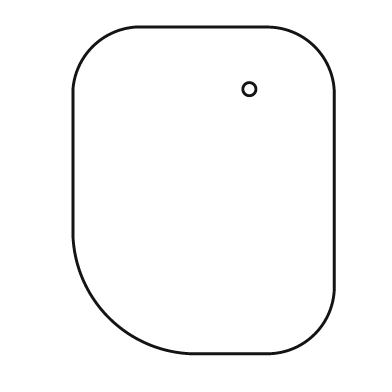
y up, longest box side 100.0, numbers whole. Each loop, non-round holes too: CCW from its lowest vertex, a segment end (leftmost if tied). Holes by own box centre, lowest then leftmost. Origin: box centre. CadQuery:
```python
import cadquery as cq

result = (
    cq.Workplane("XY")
    .moveTo(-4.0, -50.0)
    .lineTo(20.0, -50.0)
    .threePointArc((34.0, -44.0), (40.0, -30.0))
    .lineTo(40.0, 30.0)
    .threePointArc((34.0, 44.0), (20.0, 50.0))
    .lineTo(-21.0, 50.0)
    .threePointArc((-34.0, 44.0), (-40.0, 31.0))
    .lineTo(-40.0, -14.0)
    .threePointArc((-29.0, -39.0), (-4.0, -50.0))
    .close()
    .moveTo(14.0, 31.0)
    .circle(2.0)
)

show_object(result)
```